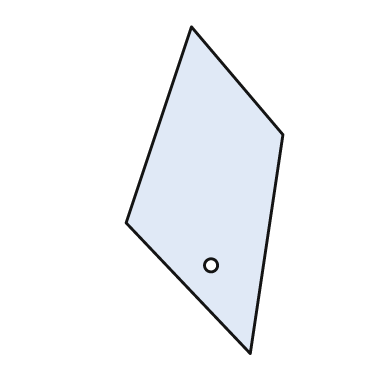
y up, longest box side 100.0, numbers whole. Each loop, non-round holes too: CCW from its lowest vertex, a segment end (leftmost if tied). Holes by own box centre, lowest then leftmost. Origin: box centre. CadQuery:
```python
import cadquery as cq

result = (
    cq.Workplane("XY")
    .moveTo(14.0, -50.0)
    .lineTo(24.0, 17.0)
    .lineTo(-4.0, 50.0)
    .lineTo(-24.0, -10.0)
    .close()
    .moveTo(2.0, -23.0)
    .circle(2.0)
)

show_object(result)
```